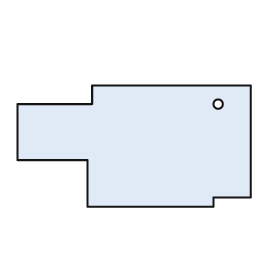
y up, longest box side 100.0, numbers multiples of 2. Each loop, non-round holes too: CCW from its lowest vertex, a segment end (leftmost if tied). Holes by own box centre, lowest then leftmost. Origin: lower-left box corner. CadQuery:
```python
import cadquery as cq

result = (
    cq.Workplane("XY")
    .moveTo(30.0, 0.0)
    .lineTo(84.0, 0.0)
    .lineTo(84.0, 4.0)
    .lineTo(100.0, 4.0)
    .lineTo(100.0, 52.0)
    .lineTo(32.0, 52.0)
    .lineTo(32.0, 44.0)
    .lineTo(0.0, 44.0)
    .lineTo(0.0, 20.0)
    .lineTo(30.0, 20.0)
    .close()
    .moveTo(86.0, 44.0)
    .circle(2.0)
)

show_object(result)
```